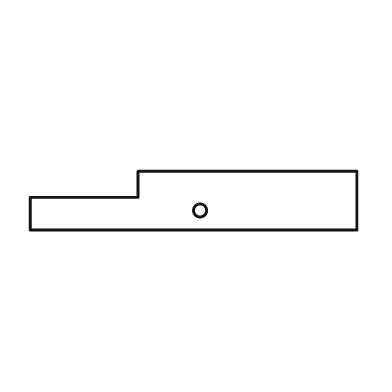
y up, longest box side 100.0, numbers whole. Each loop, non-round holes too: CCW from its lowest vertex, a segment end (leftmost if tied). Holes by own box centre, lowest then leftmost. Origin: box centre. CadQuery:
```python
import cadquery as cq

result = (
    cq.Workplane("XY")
    .moveTo(-50.0, -9.0)
    .lineTo(50.0, -9.0)
    .lineTo(50.0, 9.0)
    .lineTo(-17.0, 9.0)
    .lineTo(-17.0, 1.0)
    .lineTo(-50.0, 1.0)
    .close()
    .moveTo(2.0, -3.0)
    .circle(2.0)
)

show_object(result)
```